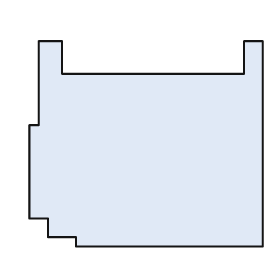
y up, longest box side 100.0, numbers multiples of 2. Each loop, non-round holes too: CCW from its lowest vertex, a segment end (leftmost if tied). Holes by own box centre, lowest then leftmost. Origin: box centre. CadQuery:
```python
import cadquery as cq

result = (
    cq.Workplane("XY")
    .moveTo(-30.0, -44.0)
    .lineTo(50.0, -44.0)
    .lineTo(50.0, 44.0)
    .lineTo(42.0, 44.0)
    .lineTo(42.0, 30.0)
    .lineTo(-36.0, 30.0)
    .lineTo(-36.0, 44.0)
    .lineTo(-46.0, 44.0)
    .lineTo(-46.0, 8.0)
    .lineTo(-50.0, 8.0)
    .lineTo(-50.0, -32.0)
    .lineTo(-42.0, -32.0)
    .lineTo(-42.0, -40.0)
    .lineTo(-30.0, -40.0)
    .close()
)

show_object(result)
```